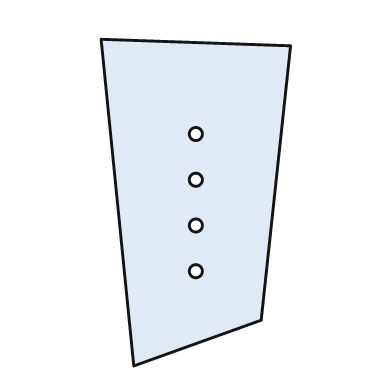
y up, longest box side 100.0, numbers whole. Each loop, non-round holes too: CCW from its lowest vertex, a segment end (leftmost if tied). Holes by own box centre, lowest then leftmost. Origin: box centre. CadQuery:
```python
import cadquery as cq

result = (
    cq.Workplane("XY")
    .moveTo(-19.0, -50.0)
    .lineTo(20.0, -36.0)
    .lineTo(29.0, 48.0)
    .lineTo(-29.0, 50.0)
    .close()
    .moveTo(0.0, -21.0)
    .circle(2.0)
    .moveTo(0.0, -7.0)
    .circle(2.0)
    .moveTo(0.0, 7.0)
    .circle(2.0)
    .moveTo(0.0, 21.0)
    .circle(2.0)
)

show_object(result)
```